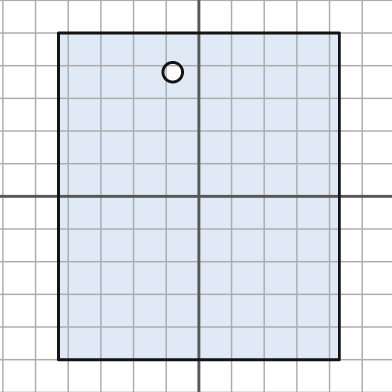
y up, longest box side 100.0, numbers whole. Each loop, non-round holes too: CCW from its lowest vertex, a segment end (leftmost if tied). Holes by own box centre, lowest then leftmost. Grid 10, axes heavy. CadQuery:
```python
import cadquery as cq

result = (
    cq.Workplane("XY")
    .moveTo(-43.0, -50.0)
    .lineTo(43.0, -50.0)
    .lineTo(43.0, 50.0)
    .lineTo(-43.0, 50.0)
    .close()
    .moveTo(-8.0, 38.0)
    .circle(3.0)
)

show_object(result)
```